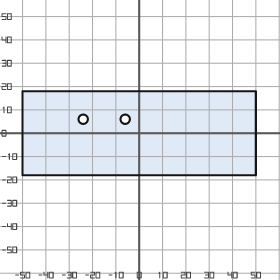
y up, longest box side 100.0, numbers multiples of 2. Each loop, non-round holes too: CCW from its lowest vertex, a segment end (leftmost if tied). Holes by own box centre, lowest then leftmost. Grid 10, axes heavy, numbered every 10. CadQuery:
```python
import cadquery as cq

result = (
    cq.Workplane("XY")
    .moveTo(-50.0, -18.0)
    .lineTo(50.0, -18.0)
    .lineTo(50.0, 18.0)
    .lineTo(-50.0, 18.0)
    .close()
    .moveTo(-24.0, 6.0)
    .circle(2.0)
    .moveTo(-6.0, 6.0)
    .circle(2.0)
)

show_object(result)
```